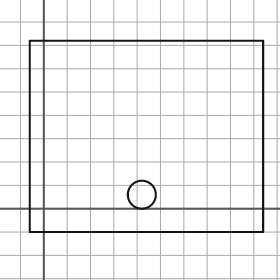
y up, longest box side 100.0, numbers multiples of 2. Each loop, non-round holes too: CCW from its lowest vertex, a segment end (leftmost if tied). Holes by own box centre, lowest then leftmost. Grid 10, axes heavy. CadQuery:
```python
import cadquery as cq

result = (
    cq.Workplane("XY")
    .moveTo(-6.0, -10.0)
    .lineTo(94.0, -10.0)
    .lineTo(94.0, 72.0)
    .lineTo(-6.0, 72.0)
    .close()
    .moveTo(42.0, 6.0)
    .circle(6.0)
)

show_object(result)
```